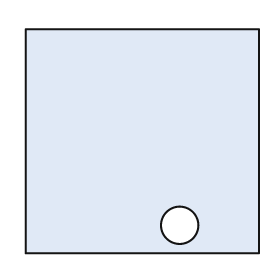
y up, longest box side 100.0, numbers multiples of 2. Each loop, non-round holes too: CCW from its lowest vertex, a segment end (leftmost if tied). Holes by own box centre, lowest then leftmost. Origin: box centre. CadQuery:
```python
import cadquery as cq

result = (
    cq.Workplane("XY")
    .moveTo(-50.0, -48.0)
    .lineTo(50.0, -48.0)
    .lineTo(50.0, 48.0)
    .lineTo(-50.0, 48.0)
    .close()
    .moveTo(16.0, -36.0)
    .circle(8.0)
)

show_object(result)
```